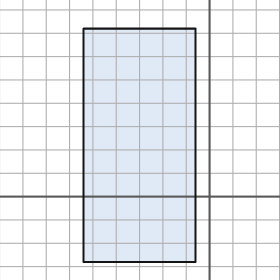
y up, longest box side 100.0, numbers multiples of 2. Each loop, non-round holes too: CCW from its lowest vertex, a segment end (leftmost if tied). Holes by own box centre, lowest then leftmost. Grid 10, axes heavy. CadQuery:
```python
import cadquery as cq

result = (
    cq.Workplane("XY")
    .moveTo(-54.0, -28.0)
    .lineTo(-6.0, -28.0)
    .lineTo(-6.0, 72.0)
    .lineTo(-54.0, 72.0)
    .close()
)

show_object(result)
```